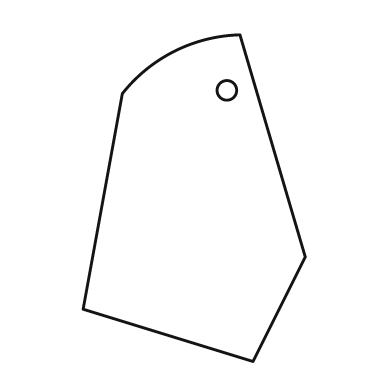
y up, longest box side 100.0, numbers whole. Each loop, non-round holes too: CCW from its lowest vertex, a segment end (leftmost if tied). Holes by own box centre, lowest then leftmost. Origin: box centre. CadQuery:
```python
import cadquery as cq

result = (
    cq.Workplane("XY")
    .moveTo(18.0, -50.0)
    .lineTo(34.0, -18.0)
    .lineTo(14.0, 50.0)
    .threePointArc((-6.0, 45.0), (-22.0, 32.0))
    .lineTo(-34.0, -34.0)
    .close()
    .moveTo(10.0, 33.0)
    .circle(3.0)
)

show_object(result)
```